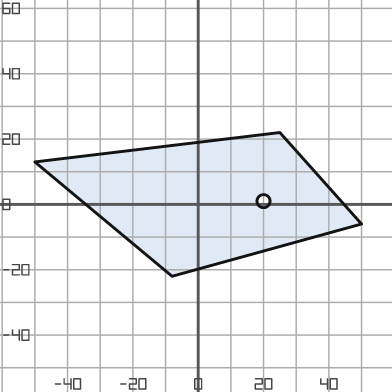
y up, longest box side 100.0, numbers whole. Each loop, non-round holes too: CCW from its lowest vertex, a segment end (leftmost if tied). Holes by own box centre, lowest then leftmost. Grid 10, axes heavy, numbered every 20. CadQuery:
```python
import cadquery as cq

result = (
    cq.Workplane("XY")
    .moveTo(-8.0, -22.0)
    .lineTo(50.0, -6.0)
    .lineTo(25.0, 22.0)
    .lineTo(-50.0, 13.0)
    .close()
    .moveTo(20.0, 1.0)
    .circle(2.0)
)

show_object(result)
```